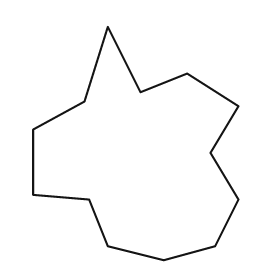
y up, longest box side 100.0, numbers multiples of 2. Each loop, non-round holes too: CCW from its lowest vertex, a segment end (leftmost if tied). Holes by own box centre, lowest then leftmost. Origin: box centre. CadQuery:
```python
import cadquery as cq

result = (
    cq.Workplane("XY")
    .moveTo(12.0, -50.0)
    .lineTo(34.0, -44.0)
    .lineTo(44.0, -24.0)
    .lineTo(32.0, -4.0)
    .lineTo(44.0, 16.0)
    .lineTo(22.0, 30.0)
    .lineTo(2.0, 22.0)
    .lineTo(-12.0, 50.0)
    .lineTo(-22.0, 18.0)
    .lineTo(-44.0, 6.0)
    .lineTo(-44.0, -22.0)
    .lineTo(-20.0, -24.0)
    .lineTo(-12.0, -44.0)
    .close()
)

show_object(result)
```